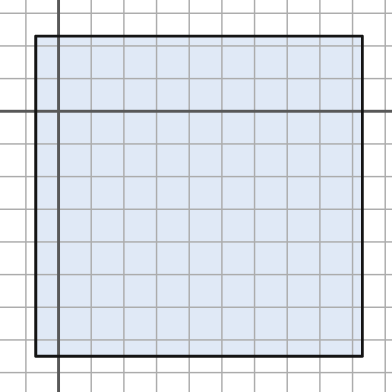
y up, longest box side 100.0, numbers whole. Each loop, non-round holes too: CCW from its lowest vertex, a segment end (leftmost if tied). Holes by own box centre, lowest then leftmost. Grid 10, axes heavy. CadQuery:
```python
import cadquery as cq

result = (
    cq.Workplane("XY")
    .moveTo(-7.0, -75.0)
    .lineTo(93.0, -75.0)
    .lineTo(93.0, 23.0)
    .lineTo(-7.0, 23.0)
    .close()
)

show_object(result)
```